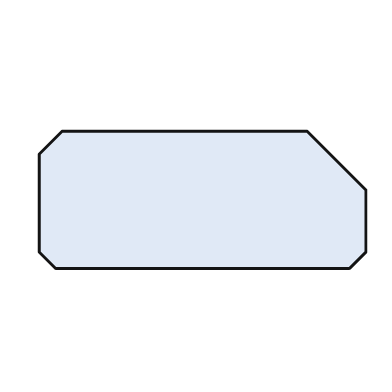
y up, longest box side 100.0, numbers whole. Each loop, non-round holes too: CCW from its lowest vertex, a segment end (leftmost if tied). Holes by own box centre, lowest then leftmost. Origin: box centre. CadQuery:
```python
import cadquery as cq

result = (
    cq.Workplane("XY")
    .moveTo(-45.0, -21.0)
    .lineTo(45.0, -21.0)
    .lineTo(50.0, -16.0)
    .lineTo(50.0, 3.0)
    .lineTo(32.0, 21.0)
    .lineTo(-43.0, 21.0)
    .lineTo(-50.0, 14.0)
    .lineTo(-50.0, -16.0)
    .close()
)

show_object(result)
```